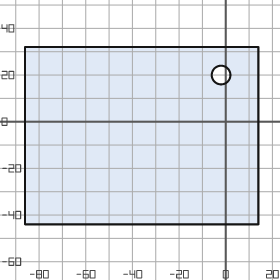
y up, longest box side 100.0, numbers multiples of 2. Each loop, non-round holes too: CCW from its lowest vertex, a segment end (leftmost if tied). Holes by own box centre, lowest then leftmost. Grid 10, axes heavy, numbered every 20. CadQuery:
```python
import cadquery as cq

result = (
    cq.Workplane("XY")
    .moveTo(-86.0, -44.0)
    .lineTo(14.0, -44.0)
    .lineTo(14.0, 32.0)
    .lineTo(-86.0, 32.0)
    .close()
    .moveTo(-2.0, 20.0)
    .circle(4.0)
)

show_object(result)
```